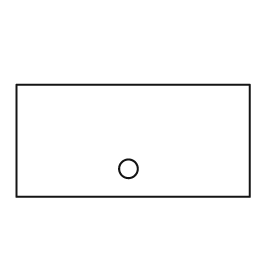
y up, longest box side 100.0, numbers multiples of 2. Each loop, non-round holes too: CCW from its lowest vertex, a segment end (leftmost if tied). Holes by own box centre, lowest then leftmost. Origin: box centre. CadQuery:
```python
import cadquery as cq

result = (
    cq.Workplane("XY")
    .moveTo(-50.0, -24.0)
    .lineTo(50.0, -24.0)
    .lineTo(50.0, 24.0)
    .lineTo(-50.0, 24.0)
    .close()
    .moveTo(-2.0, -12.0)
    .circle(4.0)
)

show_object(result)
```